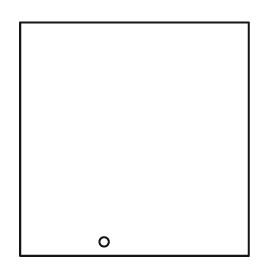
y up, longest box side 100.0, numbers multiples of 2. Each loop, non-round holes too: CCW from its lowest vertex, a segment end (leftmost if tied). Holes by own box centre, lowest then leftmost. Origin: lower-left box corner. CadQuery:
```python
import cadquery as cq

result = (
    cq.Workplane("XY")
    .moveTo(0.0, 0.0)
    .lineTo(98.0, 0.0)
    .lineTo(98.0, 100.0)
    .lineTo(0.0, 100.0)
    .close()
    .moveTo(36.0, 6.0)
    .circle(2.0)
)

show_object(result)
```